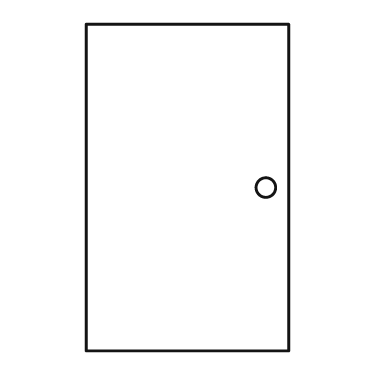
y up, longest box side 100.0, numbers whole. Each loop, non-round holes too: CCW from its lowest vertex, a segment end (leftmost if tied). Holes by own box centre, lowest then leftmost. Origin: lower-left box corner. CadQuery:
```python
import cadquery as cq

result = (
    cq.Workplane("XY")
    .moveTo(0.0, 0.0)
    .lineTo(62.0, 0.0)
    .lineTo(62.0, 100.0)
    .lineTo(0.0, 100.0)
    .close()
    .moveTo(55.0, 50.0)
    .circle(3.0)
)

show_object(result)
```